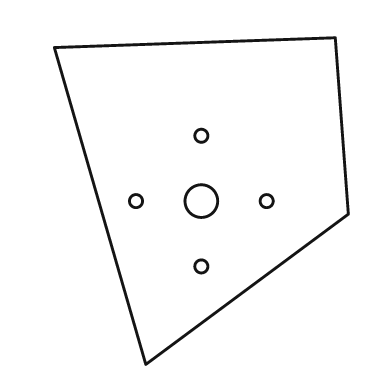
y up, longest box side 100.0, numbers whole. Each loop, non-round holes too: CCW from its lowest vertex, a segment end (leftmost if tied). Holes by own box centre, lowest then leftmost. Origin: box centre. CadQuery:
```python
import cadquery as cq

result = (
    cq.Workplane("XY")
    .moveTo(-17.0, -50.0)
    .lineTo(45.0, -4.0)
    .lineTo(41.0, 50.0)
    .lineTo(-45.0, 47.0)
    .close()
    .moveTo(0.0, -20.0)
    .circle(2.0)
    .moveTo(-20.0, 0.0)
    .circle(2.0)
    .moveTo(0.0, 0.0)
    .circle(5.0)
    .moveTo(20.0, 0.0)
    .circle(2.0)
    .moveTo(0.0, 20.0)
    .circle(2.0)
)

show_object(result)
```